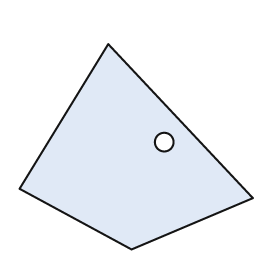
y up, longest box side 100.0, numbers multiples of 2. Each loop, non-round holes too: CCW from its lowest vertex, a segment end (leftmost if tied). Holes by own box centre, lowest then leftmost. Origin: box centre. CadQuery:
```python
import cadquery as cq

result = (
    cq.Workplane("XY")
    .moveTo(-2.0, -44.0)
    .lineTo(50.0, -22.0)
    .lineTo(-12.0, 44.0)
    .lineTo(-50.0, -18.0)
    .close()
    .moveTo(12.0, 2.0)
    .circle(4.0)
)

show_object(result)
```